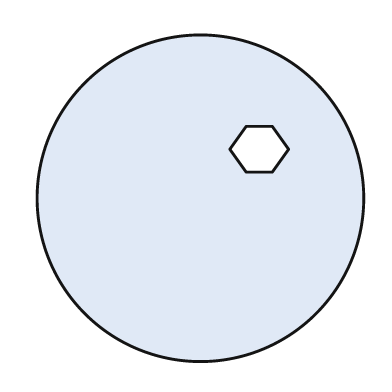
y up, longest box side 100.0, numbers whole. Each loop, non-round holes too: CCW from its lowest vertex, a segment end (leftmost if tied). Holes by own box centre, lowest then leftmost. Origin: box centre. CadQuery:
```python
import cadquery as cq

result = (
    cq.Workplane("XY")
    .moveTo(0.0, 0.0)
    .circle(50.0)
    .moveTo(14.0, 8.0)
    .lineTo(22.0, 8.0)
    .lineTo(27.0, 15.0)
    .lineTo(22.0, 22.0)
    .lineTo(14.0, 22.0)
    .lineTo(9.0, 15.0)
    .close()
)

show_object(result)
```